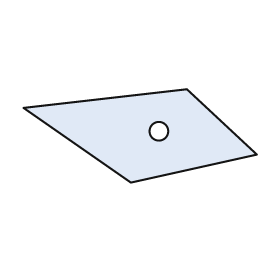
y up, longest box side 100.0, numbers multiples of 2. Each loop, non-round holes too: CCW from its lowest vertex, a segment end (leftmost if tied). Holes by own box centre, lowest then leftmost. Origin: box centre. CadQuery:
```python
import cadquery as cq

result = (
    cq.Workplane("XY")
    .moveTo(-4.0, -20.0)
    .lineTo(50.0, -8.0)
    .lineTo(20.0, 20.0)
    .lineTo(-50.0, 12.0)
    .close()
    .moveTo(8.0, 2.0)
    .circle(4.0)
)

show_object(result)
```